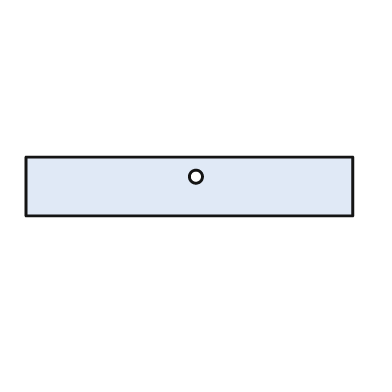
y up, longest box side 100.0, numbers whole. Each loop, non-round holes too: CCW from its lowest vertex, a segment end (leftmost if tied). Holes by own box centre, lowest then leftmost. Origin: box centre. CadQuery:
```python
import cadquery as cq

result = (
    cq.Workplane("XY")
    .moveTo(-50.0, -9.0)
    .lineTo(50.0, -9.0)
    .lineTo(50.0, 9.0)
    .lineTo(-50.0, 9.0)
    .close()
    .moveTo(2.0, 3.0)
    .circle(2.0)
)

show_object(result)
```